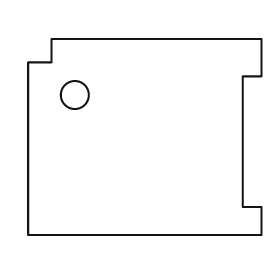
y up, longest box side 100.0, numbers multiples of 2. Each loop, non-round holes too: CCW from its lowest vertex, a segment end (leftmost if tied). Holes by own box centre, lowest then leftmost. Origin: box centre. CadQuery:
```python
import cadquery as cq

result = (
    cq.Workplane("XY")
    .moveTo(-50.0, -42.0)
    .lineTo(50.0, -42.0)
    .lineTo(50.0, -30.0)
    .lineTo(42.0, -30.0)
    .lineTo(42.0, 26.0)
    .lineTo(50.0, 26.0)
    .lineTo(50.0, 42.0)
    .lineTo(-40.0, 42.0)
    .lineTo(-40.0, 32.0)
    .lineTo(-50.0, 32.0)
    .close()
    .moveTo(-30.0, 18.0)
    .circle(6.0)
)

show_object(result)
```